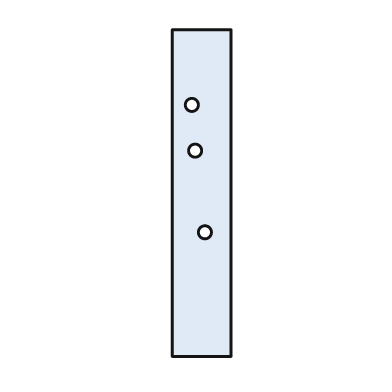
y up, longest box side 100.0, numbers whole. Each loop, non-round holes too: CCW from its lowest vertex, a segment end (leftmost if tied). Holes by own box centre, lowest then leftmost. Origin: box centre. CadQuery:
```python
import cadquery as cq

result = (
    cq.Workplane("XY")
    .moveTo(-9.0, -50.0)
    .lineTo(9.0, -50.0)
    .lineTo(9.0, 50.0)
    .lineTo(-9.0, 50.0)
    .close()
    .moveTo(1.0, -12.0)
    .circle(2.0)
    .moveTo(-2.0, 13.0)
    .circle(2.0)
    .moveTo(-3.0, 27.0)
    .circle(2.0)
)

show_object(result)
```